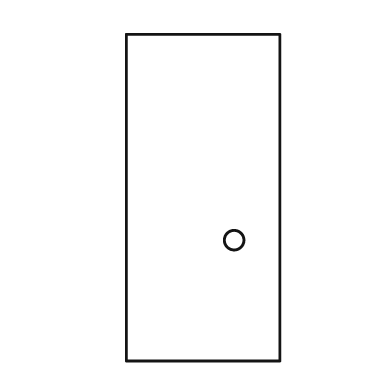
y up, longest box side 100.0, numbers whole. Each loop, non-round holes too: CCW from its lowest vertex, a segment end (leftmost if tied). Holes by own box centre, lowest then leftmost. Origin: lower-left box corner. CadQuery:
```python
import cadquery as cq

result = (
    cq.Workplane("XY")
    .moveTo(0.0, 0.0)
    .lineTo(47.0, 0.0)
    .lineTo(47.0, 100.0)
    .lineTo(0.0, 100.0)
    .close()
    .moveTo(33.0, 37.0)
    .circle(3.0)
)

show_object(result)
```